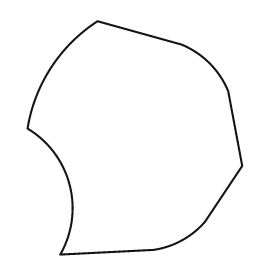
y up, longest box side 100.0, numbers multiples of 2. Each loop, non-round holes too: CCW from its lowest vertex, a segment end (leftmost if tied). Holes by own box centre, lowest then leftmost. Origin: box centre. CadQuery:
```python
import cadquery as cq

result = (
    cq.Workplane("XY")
    .moveTo(-32.0, -50.0)
    .lineTo(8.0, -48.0)
    .threePointArc((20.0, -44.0), (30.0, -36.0))
    .lineTo(46.0, -12.0)
    .lineTo(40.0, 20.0)
    .threePointArc((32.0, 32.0), (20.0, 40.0))
    .lineTo(-16.0, 50.0)
    .threePointArc((-36.0, 30.0), (-46.0, 4.0))
    .threePointArc((-28.0, -20.0), (-32.0, -50.0))
    .close()
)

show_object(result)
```